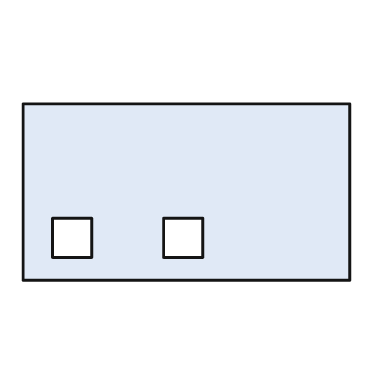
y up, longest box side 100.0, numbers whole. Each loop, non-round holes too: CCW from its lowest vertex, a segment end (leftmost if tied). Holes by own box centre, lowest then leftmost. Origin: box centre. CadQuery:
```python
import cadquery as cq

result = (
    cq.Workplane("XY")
    .moveTo(-50.0, -27.0)
    .lineTo(50.0, -27.0)
    .lineTo(50.0, 27.0)
    .lineTo(-50.0, 27.0)
    .close()
    .moveTo(-41.0, -20.0)
    .lineTo(-29.0, -20.0)
    .lineTo(-29.0, -8.0)
    .lineTo(-41.0, -8.0)
    .close()
    .moveTo(-7.0, -20.0)
    .lineTo(5.0, -20.0)
    .lineTo(5.0, -8.0)
    .lineTo(-7.0, -8.0)
    .close()
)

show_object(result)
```